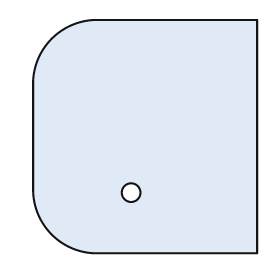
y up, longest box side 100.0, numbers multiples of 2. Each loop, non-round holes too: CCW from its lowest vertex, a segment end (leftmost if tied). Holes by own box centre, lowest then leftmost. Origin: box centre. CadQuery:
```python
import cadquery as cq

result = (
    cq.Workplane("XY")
    .moveTo(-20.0, -50.0)
    .lineTo(48.0, -50.0)
    .lineTo(48.0, 50.0)
    .lineTo(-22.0, 50.0)
    .threePointArc((-40.0, 42.0), (-48.0, 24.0))
    .lineTo(-48.0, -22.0)
    .threePointArc((-40.0, -42.0), (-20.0, -50.0))
    .close()
    .moveTo(-6.0, -24.0)
    .circle(4.0)
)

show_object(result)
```